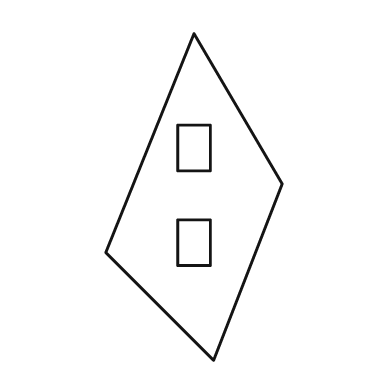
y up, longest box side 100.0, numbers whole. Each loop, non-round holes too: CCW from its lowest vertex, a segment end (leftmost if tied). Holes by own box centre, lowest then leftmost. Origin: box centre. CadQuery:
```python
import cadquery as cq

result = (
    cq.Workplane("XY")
    .moveTo(6.0, -50.0)
    .lineTo(27.0, 4.0)
    .lineTo(0.0, 50.0)
    .lineTo(-27.0, -17.0)
    .close()
    .moveTo(-5.0, -21.0)
    .lineTo(5.0, -21.0)
    .lineTo(5.0, -7.0)
    .lineTo(-5.0, -7.0)
    .close()
    .moveTo(-5.0, 8.0)
    .lineTo(5.0, 8.0)
    .lineTo(5.0, 22.0)
    .lineTo(-5.0, 22.0)
    .close()
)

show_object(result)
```